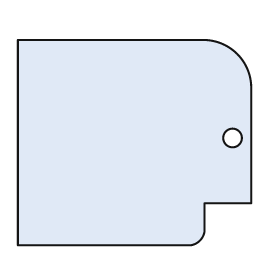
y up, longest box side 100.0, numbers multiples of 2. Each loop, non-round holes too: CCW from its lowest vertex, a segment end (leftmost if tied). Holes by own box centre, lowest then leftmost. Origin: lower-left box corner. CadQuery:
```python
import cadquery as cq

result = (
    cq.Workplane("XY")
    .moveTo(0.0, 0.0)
    .lineTo(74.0, 0.0)
    .threePointArc((78.0, 2.0), (80.0, 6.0))
    .lineTo(80.0, 18.0)
    .lineTo(100.0, 18.0)
    .lineTo(100.0, 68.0)
    .threePointArc((94.0, 82.0), (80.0, 88.0))
    .lineTo(0.0, 88.0)
    .close()
    .moveTo(92.0, 46.0)
    .circle(4.0)
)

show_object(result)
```